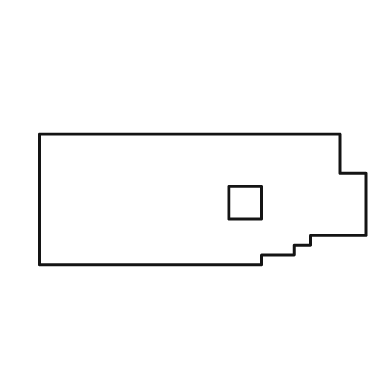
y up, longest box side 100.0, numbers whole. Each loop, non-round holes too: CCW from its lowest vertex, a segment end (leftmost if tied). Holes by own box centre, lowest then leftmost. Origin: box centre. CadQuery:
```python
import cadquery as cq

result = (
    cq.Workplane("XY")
    .moveTo(-50.0, -20.0)
    .lineTo(18.0, -20.0)
    .lineTo(18.0, -17.0)
    .lineTo(28.0, -17.0)
    .lineTo(28.0, -14.0)
    .lineTo(33.0, -14.0)
    .lineTo(33.0, -11.0)
    .lineTo(50.0, -11.0)
    .lineTo(50.0, 8.0)
    .lineTo(42.0, 8.0)
    .lineTo(42.0, 20.0)
    .lineTo(-50.0, 20.0)
    .close()
    .moveTo(8.0, -6.0)
    .lineTo(18.0, -6.0)
    .lineTo(18.0, 4.0)
    .lineTo(8.0, 4.0)
    .close()
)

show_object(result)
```